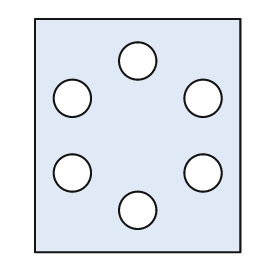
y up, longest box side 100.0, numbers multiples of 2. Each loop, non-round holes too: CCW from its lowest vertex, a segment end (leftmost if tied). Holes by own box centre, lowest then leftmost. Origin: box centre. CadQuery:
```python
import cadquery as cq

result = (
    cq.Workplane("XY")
    .moveTo(-44.0, -50.0)
    .lineTo(44.0, -50.0)
    .lineTo(44.0, 50.0)
    .lineTo(-44.0, 50.0)
    .close()
    .moveTo(0.0, -32.0)
    .circle(8.0)
    .moveTo(-28.0, -16.0)
    .circle(8.0)
    .moveTo(28.0, -16.0)
    .circle(8.0)
    .moveTo(-28.0, 16.0)
    .circle(8.0)
    .moveTo(28.0, 16.0)
    .circle(8.0)
    .moveTo(0.0, 32.0)
    .circle(8.0)
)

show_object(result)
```